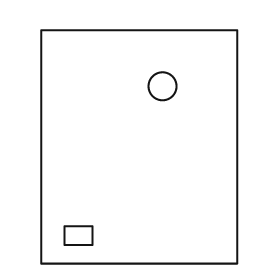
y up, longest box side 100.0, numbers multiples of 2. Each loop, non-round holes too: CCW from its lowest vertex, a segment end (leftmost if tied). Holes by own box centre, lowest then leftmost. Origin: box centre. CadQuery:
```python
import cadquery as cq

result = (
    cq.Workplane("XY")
    .moveTo(-42.0, -50.0)
    .lineTo(42.0, -50.0)
    .lineTo(42.0, 50.0)
    .lineTo(-42.0, 50.0)
    .close()
    .moveTo(-32.0, -42.0)
    .lineTo(-20.0, -42.0)
    .lineTo(-20.0, -34.0)
    .lineTo(-32.0, -34.0)
    .close()
    .moveTo(10.0, 26.0)
    .circle(6.0)
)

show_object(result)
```